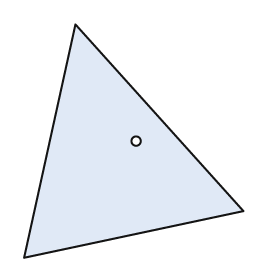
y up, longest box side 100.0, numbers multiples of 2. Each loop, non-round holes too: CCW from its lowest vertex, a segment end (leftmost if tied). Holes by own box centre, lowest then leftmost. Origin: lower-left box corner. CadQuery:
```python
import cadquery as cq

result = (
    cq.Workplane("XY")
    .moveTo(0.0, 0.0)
    .lineTo(94.0, 20.0)
    .lineTo(22.0, 100.0)
    .close()
    .moveTo(48.0, 50.0)
    .circle(2.0)
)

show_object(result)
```